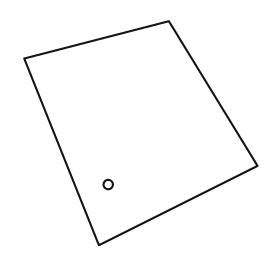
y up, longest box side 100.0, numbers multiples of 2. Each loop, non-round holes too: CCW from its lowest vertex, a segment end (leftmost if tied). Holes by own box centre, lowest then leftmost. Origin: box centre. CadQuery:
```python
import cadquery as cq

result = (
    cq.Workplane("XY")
    .moveTo(-18.0, -48.0)
    .lineTo(50.0, -14.0)
    .lineTo(12.0, 48.0)
    .lineTo(-50.0, 32.0)
    .close()
    .moveTo(-14.0, -22.0)
    .circle(2.0)
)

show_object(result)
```